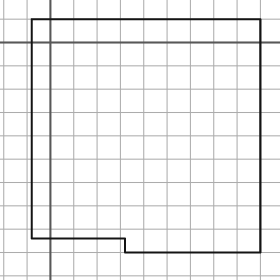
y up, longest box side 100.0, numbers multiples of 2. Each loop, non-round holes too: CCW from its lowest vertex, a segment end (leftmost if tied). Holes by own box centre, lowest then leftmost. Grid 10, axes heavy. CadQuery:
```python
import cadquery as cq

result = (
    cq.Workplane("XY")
    .moveTo(32.0, -90.0)
    .lineTo(90.0, -90.0)
    .lineTo(90.0, 10.0)
    .lineTo(-8.0, 10.0)
    .lineTo(-8.0, -84.0)
    .lineTo(32.0, -84.0)
    .close()
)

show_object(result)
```